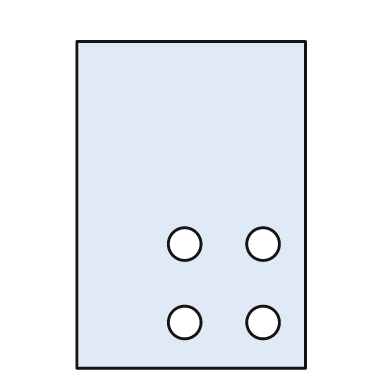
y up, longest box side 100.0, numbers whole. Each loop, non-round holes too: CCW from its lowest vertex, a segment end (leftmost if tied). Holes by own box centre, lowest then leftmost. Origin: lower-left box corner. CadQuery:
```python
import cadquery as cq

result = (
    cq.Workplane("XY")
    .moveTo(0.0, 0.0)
    .lineTo(70.0, 0.0)
    .lineTo(70.0, 100.0)
    .lineTo(0.0, 100.0)
    .close()
    .moveTo(33.0, 14.0)
    .circle(5.0)
    .moveTo(57.0, 14.0)
    .circle(5.0)
    .moveTo(33.0, 38.0)
    .circle(5.0)
    .moveTo(57.0, 38.0)
    .circle(5.0)
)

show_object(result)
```